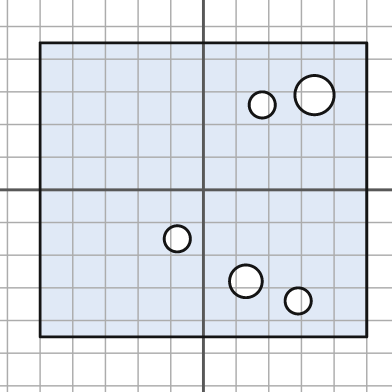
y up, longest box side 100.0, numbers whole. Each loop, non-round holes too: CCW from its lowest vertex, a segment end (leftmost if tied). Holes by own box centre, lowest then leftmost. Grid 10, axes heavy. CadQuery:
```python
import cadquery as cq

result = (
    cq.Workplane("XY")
    .moveTo(-50.0, -45.0)
    .lineTo(50.0, -45.0)
    .lineTo(50.0, 45.0)
    .lineTo(-50.0, 45.0)
    .close()
    .moveTo(29.0, -34.0)
    .circle(4.0)
    .moveTo(13.0, -28.0)
    .circle(5.0)
    .moveTo(-8.0, -15.0)
    .circle(4.0)
    .moveTo(18.0, 26.0)
    .circle(4.0)
    .moveTo(34.0, 29.0)
    .circle(6.0)
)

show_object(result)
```